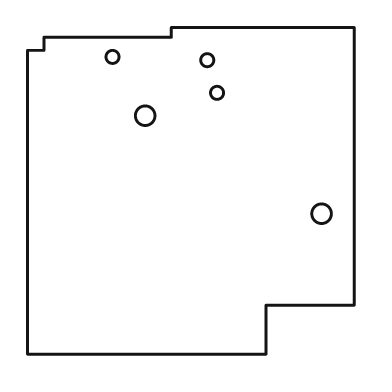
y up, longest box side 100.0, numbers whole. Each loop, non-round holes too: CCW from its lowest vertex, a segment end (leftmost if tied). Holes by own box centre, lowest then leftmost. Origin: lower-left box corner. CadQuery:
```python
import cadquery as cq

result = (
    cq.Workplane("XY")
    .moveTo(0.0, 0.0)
    .lineTo(73.0, 0.0)
    .lineTo(73.0, 15.0)
    .lineTo(100.0, 15.0)
    .lineTo(100.0, 100.0)
    .lineTo(44.0, 100.0)
    .lineTo(44.0, 97.0)
    .lineTo(5.0, 97.0)
    .lineTo(5.0, 93.0)
    .lineTo(0.0, 93.0)
    .close()
    .moveTo(90.0, 43.0)
    .circle(3.0)
    .moveTo(36.0, 73.0)
    .circle(3.0)
    .moveTo(58.0, 80.0)
    .circle(2.0)
    .moveTo(55.0, 90.0)
    .circle(2.0)
    .moveTo(26.0, 91.0)
    .circle(2.0)
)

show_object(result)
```